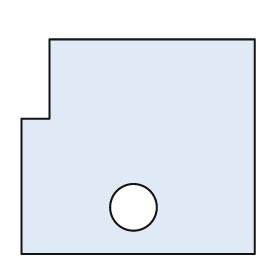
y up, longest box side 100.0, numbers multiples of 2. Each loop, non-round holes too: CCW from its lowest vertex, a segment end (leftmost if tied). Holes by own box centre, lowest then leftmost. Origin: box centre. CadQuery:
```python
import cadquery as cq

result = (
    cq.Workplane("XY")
    .moveTo(-50.0, -46.0)
    .lineTo(50.0, -46.0)
    .lineTo(50.0, 46.0)
    .lineTo(-38.0, 46.0)
    .lineTo(-38.0, 12.0)
    .lineTo(-50.0, 12.0)
    .close()
    .moveTo(-2.0, -26.0)
    .circle(10.0)
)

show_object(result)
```